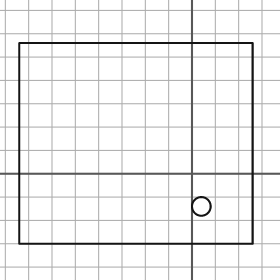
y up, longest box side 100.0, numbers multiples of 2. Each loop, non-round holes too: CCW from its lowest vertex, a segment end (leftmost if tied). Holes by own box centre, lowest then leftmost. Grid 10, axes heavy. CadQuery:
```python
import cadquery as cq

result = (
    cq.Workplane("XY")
    .moveTo(-74.0, -30.0)
    .lineTo(26.0, -30.0)
    .lineTo(26.0, 56.0)
    .lineTo(-74.0, 56.0)
    .close()
    .moveTo(4.0, -14.0)
    .circle(4.0)
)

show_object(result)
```